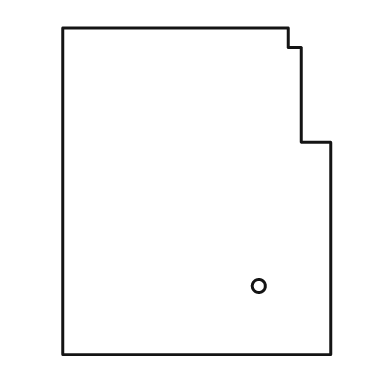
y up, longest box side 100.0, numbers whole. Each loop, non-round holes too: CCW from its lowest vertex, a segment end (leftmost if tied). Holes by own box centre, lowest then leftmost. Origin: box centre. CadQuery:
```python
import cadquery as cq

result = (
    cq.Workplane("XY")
    .moveTo(-41.0, -50.0)
    .lineTo(41.0, -50.0)
    .lineTo(41.0, 15.0)
    .lineTo(32.0, 15.0)
    .lineTo(32.0, 44.0)
    .lineTo(28.0, 44.0)
    .lineTo(28.0, 50.0)
    .lineTo(-41.0, 50.0)
    .close()
    .moveTo(19.0, -29.0)
    .circle(2.0)
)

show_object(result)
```